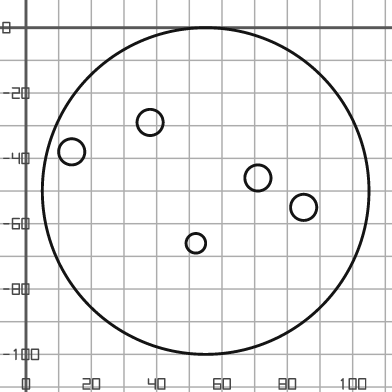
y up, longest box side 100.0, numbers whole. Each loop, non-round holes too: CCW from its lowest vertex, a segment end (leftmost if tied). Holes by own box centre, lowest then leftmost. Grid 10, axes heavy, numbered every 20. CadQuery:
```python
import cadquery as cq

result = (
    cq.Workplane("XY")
    .moveTo(55.0, -50.0)
    .circle(50.0)
    .moveTo(52.0, -66.0)
    .circle(3.0)
    .moveTo(85.0, -55.0)
    .circle(4.0)
    .moveTo(71.0, -46.0)
    .circle(4.0)
    .moveTo(14.0, -38.0)
    .circle(4.0)
    .moveTo(38.0, -29.0)
    .circle(4.0)
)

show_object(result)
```